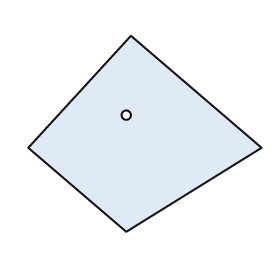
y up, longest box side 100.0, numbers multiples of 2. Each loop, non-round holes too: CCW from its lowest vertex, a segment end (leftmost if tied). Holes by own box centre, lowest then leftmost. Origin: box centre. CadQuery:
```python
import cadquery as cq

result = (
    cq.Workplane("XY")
    .moveTo(-8.0, -42.0)
    .lineTo(50.0, -6.0)
    .lineTo(-6.0, 42.0)
    .lineTo(-50.0, -6.0)
    .close()
    .moveTo(-8.0, 8.0)
    .circle(2.0)
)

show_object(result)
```